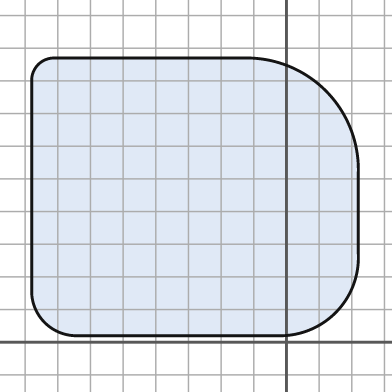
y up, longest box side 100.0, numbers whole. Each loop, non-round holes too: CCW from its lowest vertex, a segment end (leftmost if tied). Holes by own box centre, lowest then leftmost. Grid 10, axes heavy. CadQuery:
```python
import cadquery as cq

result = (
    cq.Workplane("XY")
    .moveTo(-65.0, 2.0)
    .lineTo(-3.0, 2.0)
    .threePointArc((15.0, 9.0), (22.0, 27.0))
    .lineTo(22.0, 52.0)
    .threePointArc((12.0, 77.0), (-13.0, 87.0))
    .lineTo(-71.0, 87.0)
    .threePointArc((-76.0, 85.0), (-78.0, 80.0))
    .lineTo(-78.0, 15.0)
    .threePointArc((-74.0, 6.0), (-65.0, 2.0))
    .close()
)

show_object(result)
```